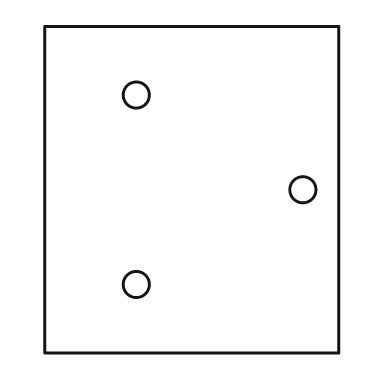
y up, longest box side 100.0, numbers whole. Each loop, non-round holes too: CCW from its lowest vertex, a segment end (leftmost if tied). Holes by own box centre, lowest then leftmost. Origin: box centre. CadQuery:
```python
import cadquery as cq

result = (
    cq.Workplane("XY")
    .moveTo(-45.0, -50.0)
    .lineTo(45.0, -50.0)
    .lineTo(45.0, 50.0)
    .lineTo(-45.0, 50.0)
    .close()
    .moveTo(-17.0, -29.0)
    .circle(4.0)
    .moveTo(34.0, 0.0)
    .circle(4.0)
    .moveTo(-17.0, 29.0)
    .circle(4.0)
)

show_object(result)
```